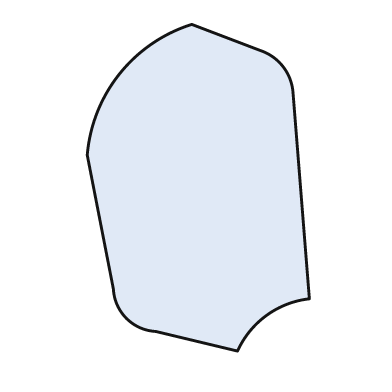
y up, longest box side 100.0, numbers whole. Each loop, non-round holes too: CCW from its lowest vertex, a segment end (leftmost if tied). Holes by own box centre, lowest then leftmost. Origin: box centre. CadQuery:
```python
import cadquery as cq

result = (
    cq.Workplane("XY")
    .moveTo(12.0, -50.0)
    .threePointArc((21.0, -39.0), (34.0, -34.0))
    .lineTo(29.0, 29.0)
    .threePointArc((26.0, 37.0), (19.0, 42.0))
    .lineTo(-2.0, 50.0)
    .threePointArc((-24.0, 35.0), (-34.0, 10.0))
    .lineTo(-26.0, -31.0)
    .threePointArc((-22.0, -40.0), (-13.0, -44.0))
    .close()
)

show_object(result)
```